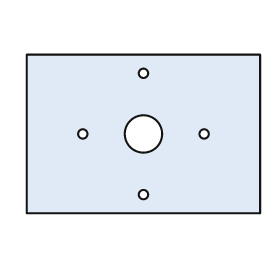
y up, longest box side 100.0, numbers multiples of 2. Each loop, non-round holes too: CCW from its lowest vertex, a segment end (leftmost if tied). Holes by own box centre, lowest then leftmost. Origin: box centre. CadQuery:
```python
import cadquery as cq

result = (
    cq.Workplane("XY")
    .moveTo(-50.0, -34.0)
    .lineTo(50.0, -34.0)
    .lineTo(50.0, 34.0)
    .lineTo(-50.0, 34.0)
    .close()
    .moveTo(0.0, -26.0)
    .circle(2.0)
    .moveTo(-26.0, 0.0)
    .circle(2.0)
    .moveTo(0.0, 0.0)
    .circle(8.0)
    .moveTo(26.0, 0.0)
    .circle(2.0)
    .moveTo(0.0, 26.0)
    .circle(2.0)
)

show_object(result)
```